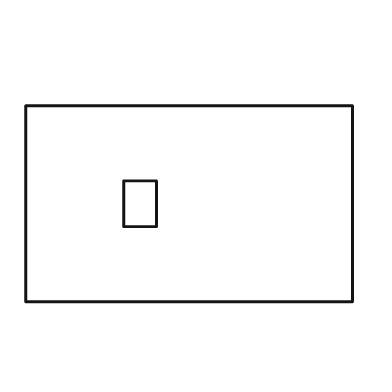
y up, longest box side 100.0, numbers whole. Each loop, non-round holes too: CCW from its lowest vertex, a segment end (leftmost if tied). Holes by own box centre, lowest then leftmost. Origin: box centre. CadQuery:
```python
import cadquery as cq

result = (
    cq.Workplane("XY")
    .moveTo(-50.0, -30.0)
    .lineTo(50.0, -30.0)
    .lineTo(50.0, 30.0)
    .lineTo(-50.0, 30.0)
    .close()
    .moveTo(-20.0, -7.0)
    .lineTo(-10.0, -7.0)
    .lineTo(-10.0, 7.0)
    .lineTo(-20.0, 7.0)
    .close()
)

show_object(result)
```